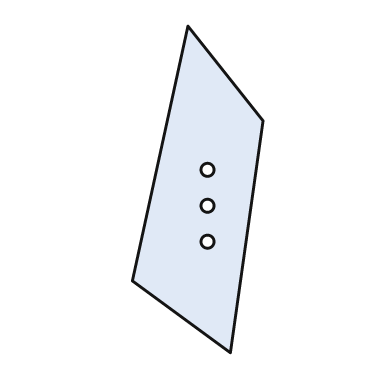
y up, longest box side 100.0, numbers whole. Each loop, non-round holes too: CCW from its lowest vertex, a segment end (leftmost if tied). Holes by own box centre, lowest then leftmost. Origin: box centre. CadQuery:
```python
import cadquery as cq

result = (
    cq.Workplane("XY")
    .moveTo(10.0, -50.0)
    .lineTo(20.0, 21.0)
    .lineTo(-3.0, 50.0)
    .lineTo(-20.0, -28.0)
    .close()
    .moveTo(3.0, -16.0)
    .circle(2.0)
    .moveTo(3.0, -5.0)
    .circle(2.0)
    .moveTo(3.0, 6.0)
    .circle(2.0)
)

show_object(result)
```